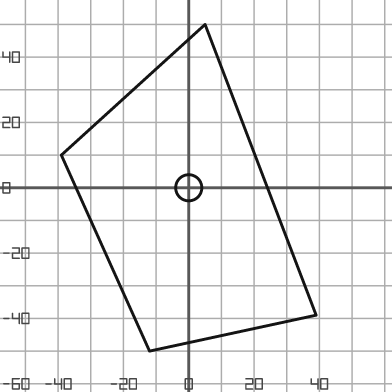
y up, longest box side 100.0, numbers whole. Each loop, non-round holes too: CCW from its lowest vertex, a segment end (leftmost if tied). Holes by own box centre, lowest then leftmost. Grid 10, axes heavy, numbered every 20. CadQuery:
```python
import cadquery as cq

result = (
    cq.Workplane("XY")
    .moveTo(-12.0, -50.0)
    .lineTo(39.0, -39.0)
    .lineTo(5.0, 50.0)
    .lineTo(-39.0, 10.0)
    .close()
    .moveTo(0.0, 0.0)
    .circle(4.0)
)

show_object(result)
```